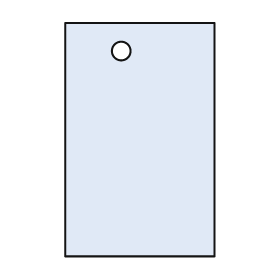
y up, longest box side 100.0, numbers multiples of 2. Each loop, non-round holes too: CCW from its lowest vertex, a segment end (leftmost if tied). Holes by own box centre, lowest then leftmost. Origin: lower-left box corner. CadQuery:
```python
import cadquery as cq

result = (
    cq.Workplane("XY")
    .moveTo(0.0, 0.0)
    .lineTo(64.0, 0.0)
    .lineTo(64.0, 100.0)
    .lineTo(0.0, 100.0)
    .close()
    .moveTo(24.0, 88.0)
    .circle(4.0)
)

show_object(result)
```